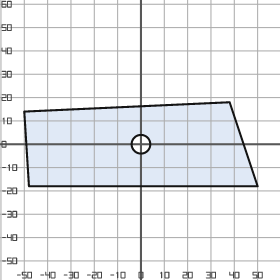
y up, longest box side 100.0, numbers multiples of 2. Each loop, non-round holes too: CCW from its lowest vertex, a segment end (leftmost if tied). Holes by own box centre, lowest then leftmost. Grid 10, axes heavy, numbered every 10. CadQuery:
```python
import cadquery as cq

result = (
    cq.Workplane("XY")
    .moveTo(-48.0, -18.0)
    .lineTo(50.0, -18.0)
    .lineTo(38.0, 18.0)
    .lineTo(-50.0, 14.0)
    .close()
    .moveTo(0.0, 0.0)
    .circle(4.0)
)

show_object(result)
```